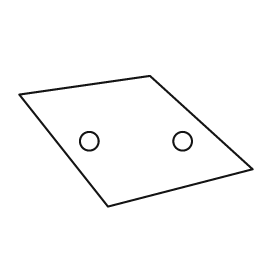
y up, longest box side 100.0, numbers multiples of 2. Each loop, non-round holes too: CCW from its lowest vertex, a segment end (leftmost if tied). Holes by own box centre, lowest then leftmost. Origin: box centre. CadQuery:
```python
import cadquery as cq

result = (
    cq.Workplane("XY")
    .moveTo(-12.0, -28.0)
    .lineTo(50.0, -12.0)
    .lineTo(6.0, 28.0)
    .lineTo(-50.0, 20.0)
    .close()
    .moveTo(-20.0, 0.0)
    .circle(4.0)
    .moveTo(20.0, 0.0)
    .circle(4.0)
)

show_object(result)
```